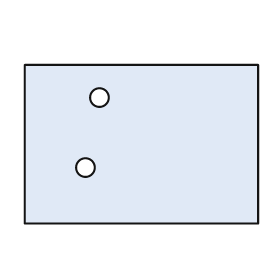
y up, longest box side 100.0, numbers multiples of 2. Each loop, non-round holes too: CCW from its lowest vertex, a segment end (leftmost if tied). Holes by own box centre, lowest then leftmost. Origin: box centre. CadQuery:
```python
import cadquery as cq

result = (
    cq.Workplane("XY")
    .moveTo(-50.0, -34.0)
    .lineTo(50.0, -34.0)
    .lineTo(50.0, 34.0)
    .lineTo(-50.0, 34.0)
    .close()
    .moveTo(-24.0, -10.0)
    .circle(4.0)
    .moveTo(-18.0, 20.0)
    .circle(4.0)
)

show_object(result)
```